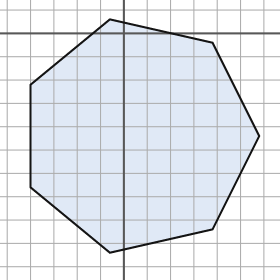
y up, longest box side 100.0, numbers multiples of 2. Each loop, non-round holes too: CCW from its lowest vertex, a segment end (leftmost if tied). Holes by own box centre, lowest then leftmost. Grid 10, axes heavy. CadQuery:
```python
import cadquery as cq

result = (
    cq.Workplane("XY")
    .moveTo(-6.0, -94.0)
    .lineTo(38.0, -84.0)
    .lineTo(58.0, -44.0)
    .lineTo(38.0, -4.0)
    .lineTo(-6.0, 6.0)
    .lineTo(-40.0, -22.0)
    .lineTo(-40.0, -66.0)
    .close()
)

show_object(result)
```